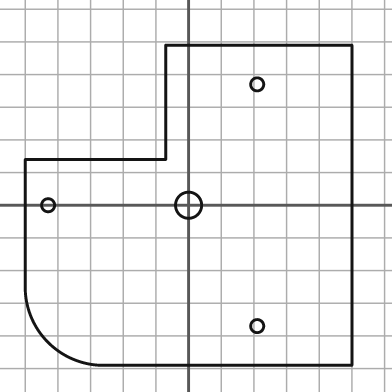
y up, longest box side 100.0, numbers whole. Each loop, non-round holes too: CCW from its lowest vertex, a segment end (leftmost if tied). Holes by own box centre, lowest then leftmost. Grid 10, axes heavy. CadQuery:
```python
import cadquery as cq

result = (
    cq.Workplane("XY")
    .moveTo(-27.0, -49.0)
    .lineTo(50.0, -49.0)
    .lineTo(50.0, 49.0)
    .lineTo(-7.0, 49.0)
    .lineTo(-7.0, 14.0)
    .lineTo(-50.0, 14.0)
    .lineTo(-50.0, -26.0)
    .threePointArc((-43.0, -42.0), (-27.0, -49.0))
    .close()
    .moveTo(21.0, -37.0)
    .circle(2.0)
    .moveTo(-43.0, 0.0)
    .circle(2.0)
    .moveTo(0.0, 0.0)
    .circle(4.0)
    .moveTo(21.0, 37.0)
    .circle(2.0)
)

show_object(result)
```